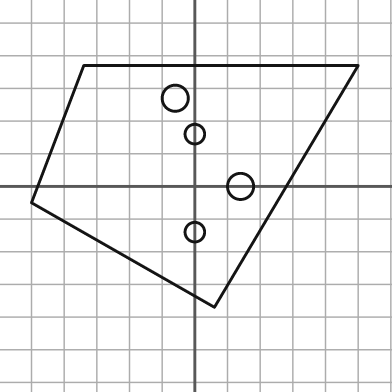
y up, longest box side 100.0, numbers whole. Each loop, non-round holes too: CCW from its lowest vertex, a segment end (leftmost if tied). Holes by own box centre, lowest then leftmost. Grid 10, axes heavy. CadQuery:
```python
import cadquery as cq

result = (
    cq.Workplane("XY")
    .moveTo(6.0, -37.0)
    .lineTo(50.0, 37.0)
    .lineTo(-34.0, 37.0)
    .lineTo(-50.0, -5.0)
    .close()
    .moveTo(0.0, -14.0)
    .circle(3.0)
    .moveTo(14.0, 0.0)
    .circle(4.0)
    .moveTo(0.0, 16.0)
    .circle(3.0)
    .moveTo(-6.0, 27.0)
    .circle(4.0)
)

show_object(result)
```